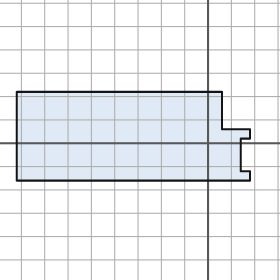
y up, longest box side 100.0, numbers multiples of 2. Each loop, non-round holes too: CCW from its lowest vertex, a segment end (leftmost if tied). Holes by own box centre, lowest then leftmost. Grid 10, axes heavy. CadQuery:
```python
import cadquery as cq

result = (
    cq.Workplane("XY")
    .moveTo(-82.0, -16.0)
    .lineTo(18.0, -16.0)
    .lineTo(18.0, -12.0)
    .lineTo(14.0, -12.0)
    .lineTo(14.0, 2.0)
    .lineTo(18.0, 2.0)
    .lineTo(18.0, 6.0)
    .lineTo(6.0, 6.0)
    .lineTo(6.0, 22.0)
    .lineTo(-82.0, 22.0)
    .close()
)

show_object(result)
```